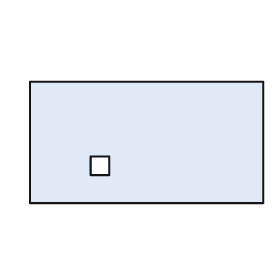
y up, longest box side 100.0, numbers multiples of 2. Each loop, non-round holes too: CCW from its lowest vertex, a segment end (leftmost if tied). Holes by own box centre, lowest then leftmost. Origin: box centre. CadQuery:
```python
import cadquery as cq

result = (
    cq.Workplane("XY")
    .moveTo(-50.0, -26.0)
    .lineTo(50.0, -26.0)
    .lineTo(50.0, 26.0)
    .lineTo(-50.0, 26.0)
    .close()
    .moveTo(-24.0, -14.0)
    .lineTo(-16.0, -14.0)
    .lineTo(-16.0, -6.0)
    .lineTo(-24.0, -6.0)
    .close()
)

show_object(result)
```